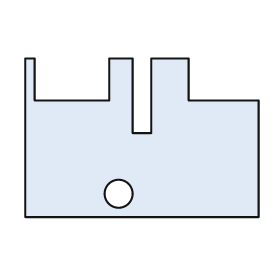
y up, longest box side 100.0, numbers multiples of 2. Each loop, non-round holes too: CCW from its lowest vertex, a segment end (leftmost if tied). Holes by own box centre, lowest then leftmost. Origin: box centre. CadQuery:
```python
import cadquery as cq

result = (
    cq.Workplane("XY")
    .moveTo(-50.0, -34.0)
    .lineTo(50.0, -34.0)
    .lineTo(50.0, 16.0)
    .lineTo(20.0, 16.0)
    .lineTo(20.0, 34.0)
    .lineTo(4.0, 34.0)
    .lineTo(4.0, 2.0)
    .lineTo(-4.0, 2.0)
    .lineTo(-4.0, 34.0)
    .lineTo(-14.0, 34.0)
    .lineTo(-14.0, 16.0)
    .lineTo(-46.0, 16.0)
    .lineTo(-46.0, 34.0)
    .lineTo(-50.0, 34.0)
    .close()
    .moveTo(-10.0, -24.0)
    .circle(6.0)
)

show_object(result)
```